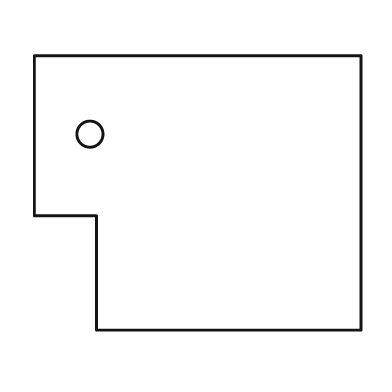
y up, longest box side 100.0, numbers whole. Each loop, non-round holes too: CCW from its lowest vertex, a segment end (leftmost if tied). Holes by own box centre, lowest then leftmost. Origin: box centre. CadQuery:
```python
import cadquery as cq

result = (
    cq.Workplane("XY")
    .moveTo(-31.0, -42.0)
    .lineTo(50.0, -42.0)
    .lineTo(50.0, 42.0)
    .lineTo(-50.0, 42.0)
    .lineTo(-50.0, -7.0)
    .lineTo(-31.0, -7.0)
    .close()
    .moveTo(-33.0, 18.0)
    .circle(4.0)
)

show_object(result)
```